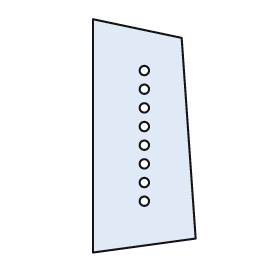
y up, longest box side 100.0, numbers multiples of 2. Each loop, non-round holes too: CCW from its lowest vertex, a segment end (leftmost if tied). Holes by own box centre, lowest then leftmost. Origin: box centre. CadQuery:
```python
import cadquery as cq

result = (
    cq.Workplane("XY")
    .moveTo(-22.0, -50.0)
    .lineTo(22.0, -44.0)
    .lineTo(16.0, 42.0)
    .lineTo(-22.0, 50.0)
    .close()
    .moveTo(0.0, -28.0)
    .circle(2.0)
    .moveTo(0.0, -20.0)
    .circle(2.0)
    .moveTo(0.0, -12.0)
    .circle(2.0)
    .moveTo(0.0, -4.0)
    .circle(2.0)
    .moveTo(0.0, 4.0)
    .circle(2.0)
    .moveTo(0.0, 12.0)
    .circle(2.0)
    .moveTo(0.0, 20.0)
    .circle(2.0)
    .moveTo(0.0, 28.0)
    .circle(2.0)
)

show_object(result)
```